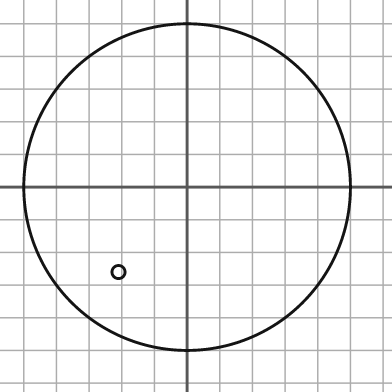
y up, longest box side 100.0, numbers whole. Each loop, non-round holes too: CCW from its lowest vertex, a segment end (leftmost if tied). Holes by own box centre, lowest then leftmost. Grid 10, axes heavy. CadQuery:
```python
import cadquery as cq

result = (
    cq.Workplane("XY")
    .moveTo(0.0, 0.0)
    .circle(50.0)
    .moveTo(-21.0, -26.0)
    .circle(2.0)
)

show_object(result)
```